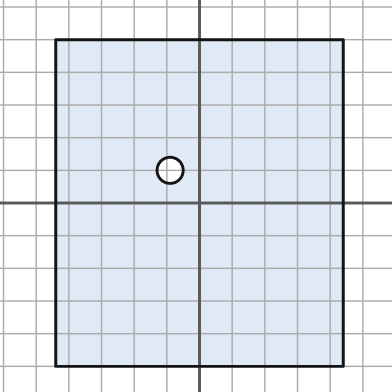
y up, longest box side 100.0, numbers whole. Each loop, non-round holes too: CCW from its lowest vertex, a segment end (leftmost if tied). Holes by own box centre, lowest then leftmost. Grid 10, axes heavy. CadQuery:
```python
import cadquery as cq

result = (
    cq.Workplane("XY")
    .moveTo(-44.0, -50.0)
    .lineTo(44.0, -50.0)
    .lineTo(44.0, 50.0)
    .lineTo(-44.0, 50.0)
    .close()
    .moveTo(-9.0, 10.0)
    .circle(4.0)
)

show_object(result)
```